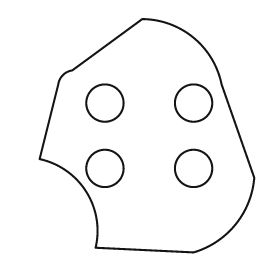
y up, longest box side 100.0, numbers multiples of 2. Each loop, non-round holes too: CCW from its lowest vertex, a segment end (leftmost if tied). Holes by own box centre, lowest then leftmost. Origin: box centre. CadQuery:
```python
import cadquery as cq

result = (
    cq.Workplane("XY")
    .moveTo(20.0, -50.0)
    .threePointArc((38.0, -38.0), (46.0, -18.0))
    .lineTo(32.0, 22.0)
    .threePointArc((20.0, 42.0), (-2.0, 50.0))
    .lineTo(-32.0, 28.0)
    .threePointArc((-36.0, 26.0), (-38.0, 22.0))
    .lineTo(-46.0, -10.0)
    .threePointArc((-26.0, -24.0), (-22.0, -48.0))
    .close()
    .moveTo(-18.0, -14.0)
    .circle(8.0)
    .moveTo(20.0, -14.0)
    .circle(8.0)
    .moveTo(-18.0, 14.0)
    .circle(8.0)
    .moveTo(20.0, 14.0)
    .circle(8.0)
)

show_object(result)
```